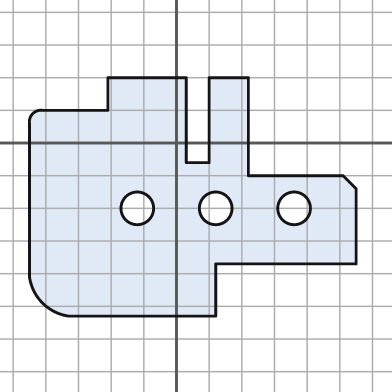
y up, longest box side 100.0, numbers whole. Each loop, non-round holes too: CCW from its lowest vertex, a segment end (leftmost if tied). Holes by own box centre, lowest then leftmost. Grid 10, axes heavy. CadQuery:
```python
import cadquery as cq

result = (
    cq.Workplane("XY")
    .moveTo(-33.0, -53.0)
    .lineTo(12.0, -53.0)
    .lineTo(12.0, -37.0)
    .lineTo(55.0, -37.0)
    .lineTo(55.0, -14.0)
    .lineTo(51.0, -10.0)
    .lineTo(22.0, -10.0)
    .lineTo(22.0, 20.0)
    .lineTo(10.0, 20.0)
    .lineTo(10.0, -6.0)
    .lineTo(3.0, -6.0)
    .lineTo(3.0, 20.0)
    .lineTo(-21.0, 20.0)
    .lineTo(-21.0, 10.0)
    .lineTo(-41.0, 10.0)
    .threePointArc((-44.0, 9.0), (-45.0, 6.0))
    .lineTo(-45.0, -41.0)
    .threePointArc((-41.0, -49.0), (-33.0, -53.0))
    .close()
    .moveTo(-12.0, -20.0)
    .circle(5.0)
    .moveTo(12.0, -20.0)
    .circle(5.0)
    .moveTo(36.0, -20.0)
    .circle(5.0)
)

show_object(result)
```